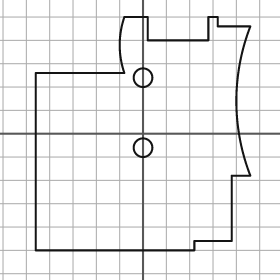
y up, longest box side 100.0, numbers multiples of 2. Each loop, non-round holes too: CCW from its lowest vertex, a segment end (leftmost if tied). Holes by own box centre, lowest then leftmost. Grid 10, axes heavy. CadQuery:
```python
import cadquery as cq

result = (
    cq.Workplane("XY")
    .moveTo(-46.0, -50.0)
    .lineTo(22.0, -50.0)
    .lineTo(22.0, -46.0)
    .lineTo(38.0, -46.0)
    .lineTo(38.0, -18.0)
    .lineTo(46.0, -18.0)
    .threePointArc((40.0, 14.0), (46.0, 46.0))
    .lineTo(32.0, 46.0)
    .lineTo(32.0, 50.0)
    .lineTo(28.0, 50.0)
    .lineTo(28.0, 40.0)
    .lineTo(2.0, 40.0)
    .lineTo(2.0, 50.0)
    .lineTo(-8.0, 50.0)
    .threePointArc((-10.0, 38.0), (-8.0, 26.0))
    .lineTo(-46.0, 26.0)
    .close()
    .moveTo(0.0, -6.0)
    .circle(4.0)
    .moveTo(0.0, 24.0)
    .circle(4.0)
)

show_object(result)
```